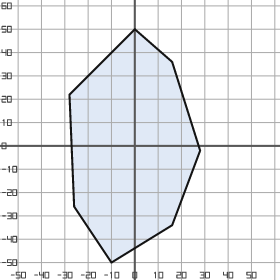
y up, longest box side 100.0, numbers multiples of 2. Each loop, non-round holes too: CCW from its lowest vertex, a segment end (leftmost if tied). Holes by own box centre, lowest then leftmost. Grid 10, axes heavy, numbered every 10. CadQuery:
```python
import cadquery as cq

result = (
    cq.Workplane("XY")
    .moveTo(-10.0, -50.0)
    .lineTo(16.0, -34.0)
    .lineTo(28.0, -2.0)
    .lineTo(16.0, 36.0)
    .lineTo(0.0, 50.0)
    .lineTo(-28.0, 22.0)
    .lineTo(-26.0, -26.0)
    .close()
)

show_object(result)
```